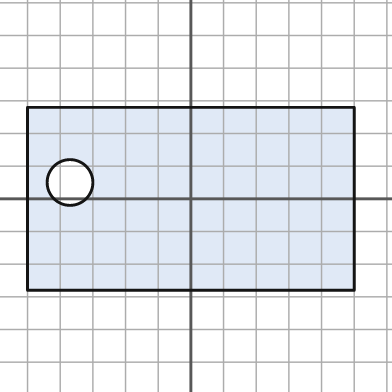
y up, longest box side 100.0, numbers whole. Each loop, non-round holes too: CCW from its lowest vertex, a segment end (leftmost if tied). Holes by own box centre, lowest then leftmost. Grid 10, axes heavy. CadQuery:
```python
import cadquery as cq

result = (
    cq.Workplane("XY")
    .moveTo(-50.0, -28.0)
    .lineTo(50.0, -28.0)
    .lineTo(50.0, 28.0)
    .lineTo(-50.0, 28.0)
    .close()
    .moveTo(-37.0, 5.0)
    .circle(7.0)
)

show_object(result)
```